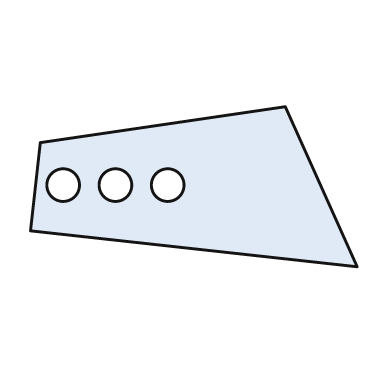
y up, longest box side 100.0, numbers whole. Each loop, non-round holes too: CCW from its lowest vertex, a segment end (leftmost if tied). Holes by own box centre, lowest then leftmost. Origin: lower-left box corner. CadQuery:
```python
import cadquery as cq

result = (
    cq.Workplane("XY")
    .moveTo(100.0, 0.0)
    .lineTo(78.0, 49.0)
    .lineTo(3.0, 38.0)
    .lineTo(0.0, 11.0)
    .close()
    .moveTo(10.0, 25.0)
    .circle(5.0)
    .moveTo(26.0, 25.0)
    .circle(5.0)
    .moveTo(42.0, 25.0)
    .circle(5.0)
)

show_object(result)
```